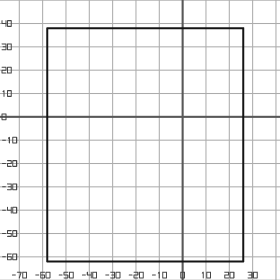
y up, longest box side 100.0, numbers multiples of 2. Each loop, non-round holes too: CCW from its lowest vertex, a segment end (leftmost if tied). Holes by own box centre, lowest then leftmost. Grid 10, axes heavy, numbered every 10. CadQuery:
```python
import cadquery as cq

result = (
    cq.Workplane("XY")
    .moveTo(-58.0, -62.0)
    .lineTo(26.0, -62.0)
    .lineTo(26.0, 38.0)
    .lineTo(-58.0, 38.0)
    .close()
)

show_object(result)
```